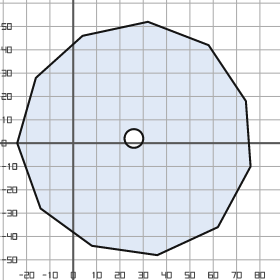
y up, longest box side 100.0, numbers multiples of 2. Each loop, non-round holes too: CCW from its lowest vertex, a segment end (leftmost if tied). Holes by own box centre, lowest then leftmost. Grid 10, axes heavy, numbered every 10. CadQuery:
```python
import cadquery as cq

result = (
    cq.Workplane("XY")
    .moveTo(36.0, -48.0)
    .lineTo(62.0, -36.0)
    .lineTo(76.0, -10.0)
    .lineTo(74.0, 18.0)
    .lineTo(58.0, 42.0)
    .lineTo(32.0, 52.0)
    .lineTo(4.0, 46.0)
    .lineTo(-16.0, 28.0)
    .lineTo(-24.0, 0.0)
    .lineTo(-14.0, -28.0)
    .lineTo(8.0, -44.0)
    .close()
    .moveTo(26.0, 2.0)
    .circle(4.0)
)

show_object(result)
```